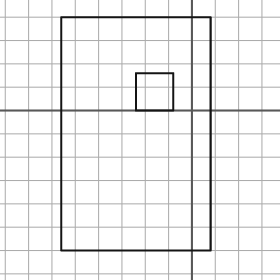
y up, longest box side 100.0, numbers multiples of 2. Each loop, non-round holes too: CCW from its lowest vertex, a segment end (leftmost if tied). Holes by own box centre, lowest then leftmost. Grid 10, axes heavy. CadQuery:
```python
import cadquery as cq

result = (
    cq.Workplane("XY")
    .moveTo(-56.0, -60.0)
    .lineTo(8.0, -60.0)
    .lineTo(8.0, 40.0)
    .lineTo(-56.0, 40.0)
    .close()
    .moveTo(-24.0, 0.0)
    .lineTo(-8.0, 0.0)
    .lineTo(-8.0, 16.0)
    .lineTo(-24.0, 16.0)
    .close()
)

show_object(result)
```